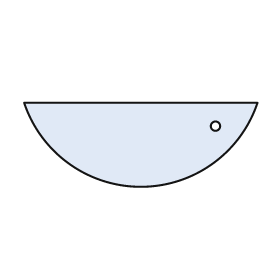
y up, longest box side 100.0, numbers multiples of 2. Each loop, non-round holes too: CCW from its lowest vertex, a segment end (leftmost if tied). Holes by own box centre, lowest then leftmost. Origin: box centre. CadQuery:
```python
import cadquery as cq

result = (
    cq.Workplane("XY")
    .moveTo(-50.0, 18.0)
    .threePointArc((0.0, -18.0), (50.0, 18.0))
    .close()
    .moveTo(32.0, 8.0)
    .circle(2.0)
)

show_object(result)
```